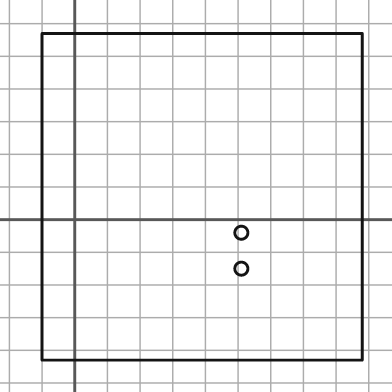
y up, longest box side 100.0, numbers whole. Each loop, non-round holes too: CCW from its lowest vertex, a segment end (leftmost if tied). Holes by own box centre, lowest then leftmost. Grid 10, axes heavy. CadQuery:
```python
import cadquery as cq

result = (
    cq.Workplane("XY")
    .moveTo(-10.0, -43.0)
    .lineTo(88.0, -43.0)
    .lineTo(88.0, 57.0)
    .lineTo(-10.0, 57.0)
    .close()
    .moveTo(51.0, -15.0)
    .circle(2.0)
    .moveTo(51.0, -4.0)
    .circle(2.0)
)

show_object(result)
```